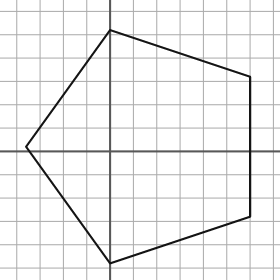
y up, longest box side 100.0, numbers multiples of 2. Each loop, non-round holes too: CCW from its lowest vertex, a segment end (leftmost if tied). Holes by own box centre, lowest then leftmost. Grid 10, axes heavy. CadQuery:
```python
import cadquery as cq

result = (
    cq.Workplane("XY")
    .moveTo(0.0, -48.0)
    .lineTo(60.0, -28.0)
    .lineTo(60.0, 32.0)
    .lineTo(0.0, 52.0)
    .lineTo(-36.0, 2.0)
    .close()
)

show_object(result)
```